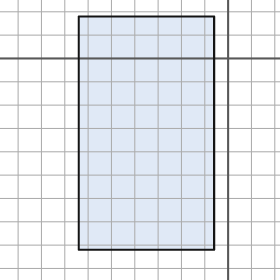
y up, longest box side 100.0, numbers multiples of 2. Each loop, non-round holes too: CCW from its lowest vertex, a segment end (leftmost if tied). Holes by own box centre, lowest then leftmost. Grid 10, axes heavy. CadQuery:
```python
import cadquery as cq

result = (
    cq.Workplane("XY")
    .moveTo(-64.0, -82.0)
    .lineTo(-6.0, -82.0)
    .lineTo(-6.0, 18.0)
    .lineTo(-64.0, 18.0)
    .close()
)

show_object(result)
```